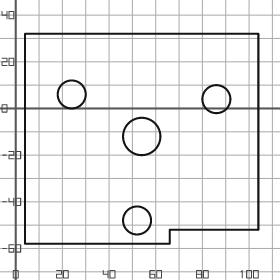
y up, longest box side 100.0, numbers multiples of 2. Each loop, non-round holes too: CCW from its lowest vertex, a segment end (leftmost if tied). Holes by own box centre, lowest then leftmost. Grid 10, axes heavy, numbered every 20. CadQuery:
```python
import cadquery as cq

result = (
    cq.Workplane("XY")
    .moveTo(4.0, -58.0)
    .lineTo(66.0, -58.0)
    .lineTo(66.0, -52.0)
    .lineTo(104.0, -52.0)
    .lineTo(104.0, 32.0)
    .lineTo(4.0, 32.0)
    .close()
    .moveTo(52.0, -48.0)
    .circle(6.0)
    .moveTo(54.0, -12.0)
    .circle(8.0)
    .moveTo(86.0, 4.0)
    .circle(6.0)
    .moveTo(24.0, 6.0)
    .circle(6.0)
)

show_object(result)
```